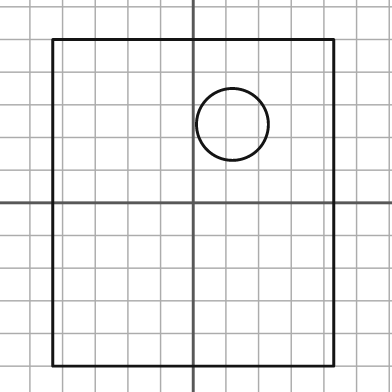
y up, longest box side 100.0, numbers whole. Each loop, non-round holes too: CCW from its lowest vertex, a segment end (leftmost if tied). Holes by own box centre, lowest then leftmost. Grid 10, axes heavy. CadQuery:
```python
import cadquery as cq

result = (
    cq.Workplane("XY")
    .moveTo(-43.0, -50.0)
    .lineTo(43.0, -50.0)
    .lineTo(43.0, 50.0)
    .lineTo(-43.0, 50.0)
    .close()
    .moveTo(12.0, 24.0)
    .circle(11.0)
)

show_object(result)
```